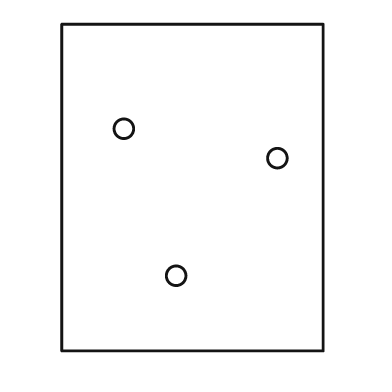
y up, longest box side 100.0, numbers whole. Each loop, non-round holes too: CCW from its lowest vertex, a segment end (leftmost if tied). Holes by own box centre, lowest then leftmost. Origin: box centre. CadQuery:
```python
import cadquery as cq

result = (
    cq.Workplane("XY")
    .moveTo(-40.0, -50.0)
    .lineTo(40.0, -50.0)
    .lineTo(40.0, 50.0)
    .lineTo(-40.0, 50.0)
    .close()
    .moveTo(-5.0, -27.0)
    .circle(3.0)
    .moveTo(26.0, 9.0)
    .circle(3.0)
    .moveTo(-21.0, 18.0)
    .circle(3.0)
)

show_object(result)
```